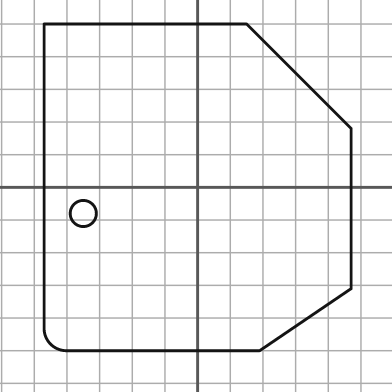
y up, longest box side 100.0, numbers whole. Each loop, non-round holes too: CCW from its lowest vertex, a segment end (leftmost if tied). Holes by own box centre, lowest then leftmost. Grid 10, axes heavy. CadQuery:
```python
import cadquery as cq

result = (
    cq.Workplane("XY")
    .moveTo(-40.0, -50.0)
    .lineTo(19.0, -50.0)
    .lineTo(47.0, -31.0)
    .lineTo(47.0, 18.0)
    .lineTo(15.0, 50.0)
    .lineTo(-47.0, 50.0)
    .lineTo(-47.0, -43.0)
    .threePointArc((-45.0, -48.0), (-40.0, -50.0))
    .close()
    .moveTo(-35.0, -8.0)
    .circle(4.0)
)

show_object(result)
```